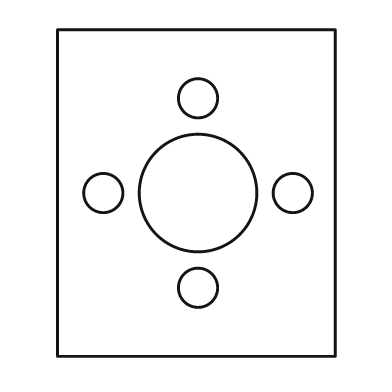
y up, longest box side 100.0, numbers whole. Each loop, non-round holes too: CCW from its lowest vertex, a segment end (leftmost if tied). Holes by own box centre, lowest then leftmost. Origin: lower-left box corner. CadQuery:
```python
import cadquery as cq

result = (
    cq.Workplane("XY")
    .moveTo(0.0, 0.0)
    .lineTo(85.0, 0.0)
    .lineTo(85.0, 100.0)
    .lineTo(0.0, 100.0)
    .close()
    .moveTo(43.0, 21.0)
    .circle(6.0)
    .moveTo(14.0, 50.0)
    .circle(6.0)
    .moveTo(43.0, 50.0)
    .circle(18.0)
    .moveTo(72.0, 50.0)
    .circle(6.0)
    .moveTo(43.0, 79.0)
    .circle(6.0)
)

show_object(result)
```